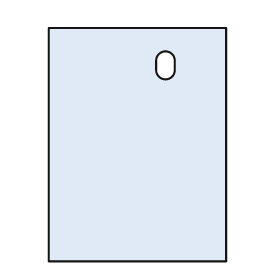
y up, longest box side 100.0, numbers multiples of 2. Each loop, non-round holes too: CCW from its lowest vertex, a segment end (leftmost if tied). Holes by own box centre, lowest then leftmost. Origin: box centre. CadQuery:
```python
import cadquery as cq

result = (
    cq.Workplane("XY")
    .moveTo(-38.0, -50.0)
    .lineTo(38.0, -50.0)
    .lineTo(38.0, 50.0)
    .lineTo(-38.0, 50.0)
    .close()
    .moveTo(8.0, 32.0)
    .threePointArc((12.0, 28.0), (16.0, 32.0))
    .lineTo(16.0, 36.0)
    .threePointArc((12.0, 40.0), (8.0, 36.0))
    .close()
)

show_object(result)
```